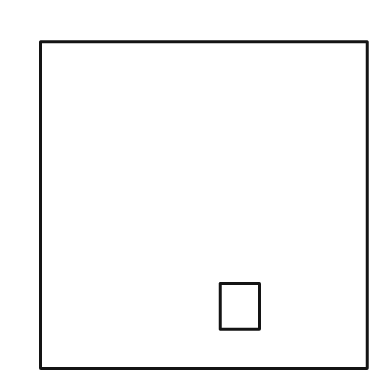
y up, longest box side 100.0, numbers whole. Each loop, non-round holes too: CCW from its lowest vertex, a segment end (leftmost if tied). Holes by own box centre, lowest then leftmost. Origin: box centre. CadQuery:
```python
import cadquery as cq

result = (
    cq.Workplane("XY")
    .moveTo(-50.0, -50.0)
    .lineTo(50.0, -50.0)
    .lineTo(50.0, 50.0)
    .lineTo(-50.0, 50.0)
    .close()
    .moveTo(5.0, -38.0)
    .lineTo(17.0, -38.0)
    .lineTo(17.0, -24.0)
    .lineTo(5.0, -24.0)
    .close()
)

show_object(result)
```